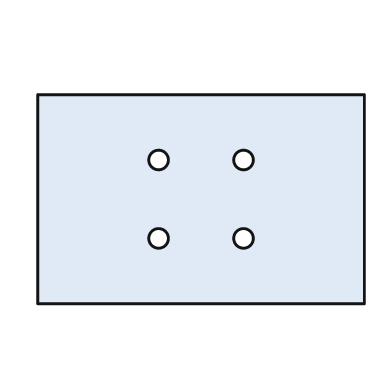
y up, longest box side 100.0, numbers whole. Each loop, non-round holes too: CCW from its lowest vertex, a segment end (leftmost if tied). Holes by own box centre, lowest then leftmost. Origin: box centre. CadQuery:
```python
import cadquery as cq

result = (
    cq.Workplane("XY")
    .moveTo(-50.0, -32.0)
    .lineTo(50.0, -32.0)
    .lineTo(50.0, 32.0)
    .lineTo(-50.0, 32.0)
    .close()
    .moveTo(-13.0, -12.0)
    .circle(3.0)
    .moveTo(13.0, -12.0)
    .circle(3.0)
    .moveTo(-13.0, 12.0)
    .circle(3.0)
    .moveTo(13.0, 12.0)
    .circle(3.0)
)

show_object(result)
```